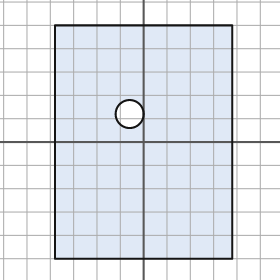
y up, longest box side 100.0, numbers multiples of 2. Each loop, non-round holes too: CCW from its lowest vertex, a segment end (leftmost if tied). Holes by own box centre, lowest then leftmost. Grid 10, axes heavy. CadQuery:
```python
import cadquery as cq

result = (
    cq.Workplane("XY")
    .moveTo(-38.0, -50.0)
    .lineTo(38.0, -50.0)
    .lineTo(38.0, 50.0)
    .lineTo(-38.0, 50.0)
    .close()
    .moveTo(-6.0, 12.0)
    .circle(6.0)
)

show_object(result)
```